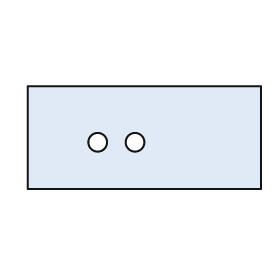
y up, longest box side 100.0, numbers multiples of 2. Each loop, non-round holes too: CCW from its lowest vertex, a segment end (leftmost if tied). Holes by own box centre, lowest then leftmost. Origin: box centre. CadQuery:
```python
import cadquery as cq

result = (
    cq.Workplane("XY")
    .moveTo(-50.0, -22.0)
    .lineTo(50.0, -22.0)
    .lineTo(50.0, 22.0)
    .lineTo(-50.0, 22.0)
    .close()
    .moveTo(-20.0, -2.0)
    .circle(4.0)
    .moveTo(-4.0, -2.0)
    .circle(4.0)
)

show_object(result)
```